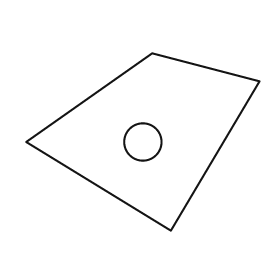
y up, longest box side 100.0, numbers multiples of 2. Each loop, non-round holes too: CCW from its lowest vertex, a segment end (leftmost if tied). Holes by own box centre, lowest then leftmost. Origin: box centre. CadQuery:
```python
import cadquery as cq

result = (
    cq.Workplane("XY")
    .moveTo(12.0, -38.0)
    .lineTo(50.0, 26.0)
    .lineTo(4.0, 38.0)
    .lineTo(-50.0, 0.0)
    .close()
    .moveTo(0.0, 0.0)
    .circle(8.0)
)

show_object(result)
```